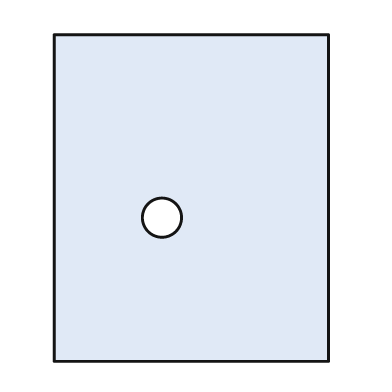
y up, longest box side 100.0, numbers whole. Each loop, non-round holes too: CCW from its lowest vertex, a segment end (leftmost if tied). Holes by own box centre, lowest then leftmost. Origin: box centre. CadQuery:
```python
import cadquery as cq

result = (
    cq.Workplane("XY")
    .moveTo(-42.0, -50.0)
    .lineTo(42.0, -50.0)
    .lineTo(42.0, 50.0)
    .lineTo(-42.0, 50.0)
    .close()
    .moveTo(-9.0, -6.0)
    .circle(6.0)
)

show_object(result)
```